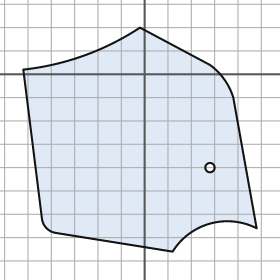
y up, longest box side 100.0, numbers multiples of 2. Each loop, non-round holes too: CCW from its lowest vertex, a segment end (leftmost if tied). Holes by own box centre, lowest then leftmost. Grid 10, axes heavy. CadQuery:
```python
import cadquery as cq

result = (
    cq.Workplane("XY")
    .moveTo(12.0, -76.0)
    .threePointArc((28.0, -64.0), (48.0, -66.0))
    .lineTo(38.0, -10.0)
    .threePointArc((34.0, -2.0), (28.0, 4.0))
    .lineTo(-2.0, 20.0)
    .threePointArc((-26.0, 8.0), (-52.0, 2.0))
    .lineTo(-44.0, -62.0)
    .threePointArc((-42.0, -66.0), (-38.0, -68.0))
    .close()
    .moveTo(28.0, -40.0)
    .circle(2.0)
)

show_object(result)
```